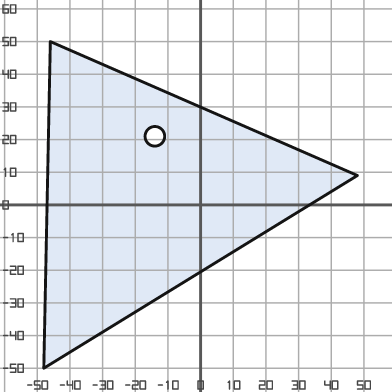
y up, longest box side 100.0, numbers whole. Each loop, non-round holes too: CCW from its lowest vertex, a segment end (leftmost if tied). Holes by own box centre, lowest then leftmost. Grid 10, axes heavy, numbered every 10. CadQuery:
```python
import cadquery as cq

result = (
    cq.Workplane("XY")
    .moveTo(-48.0, -50.0)
    .lineTo(48.0, 9.0)
    .lineTo(-46.0, 50.0)
    .close()
    .moveTo(-14.0, 21.0)
    .circle(3.0)
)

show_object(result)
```